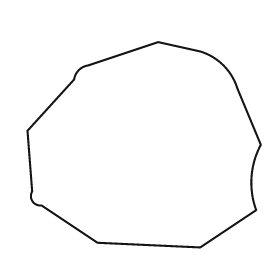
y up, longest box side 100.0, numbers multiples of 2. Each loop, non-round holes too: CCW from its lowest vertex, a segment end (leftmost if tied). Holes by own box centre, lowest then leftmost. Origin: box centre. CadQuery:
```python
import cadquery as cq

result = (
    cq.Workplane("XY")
    .moveTo(24.0, -44.0)
    .lineTo(48.0, -28.0)
    .threePointArc((46.0, -14.0), (50.0, 0.0))
    .lineTo(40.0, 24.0)
    .threePointArc((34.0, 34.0), (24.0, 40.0))
    .lineTo(6.0, 44.0)
    .lineTo(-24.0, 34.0)
    .threePointArc((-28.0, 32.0), (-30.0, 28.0))
    .lineTo(-50.0, 6.0)
    .lineTo(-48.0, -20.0)
    .threePointArc((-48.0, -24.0), (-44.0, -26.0))
    .lineTo(-20.0, -42.0)
    .close()
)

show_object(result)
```